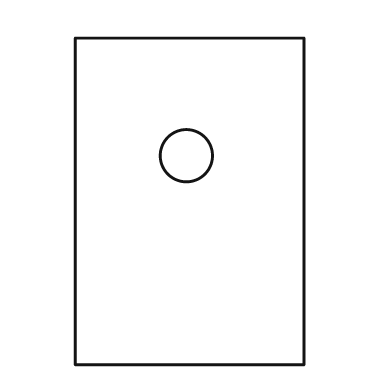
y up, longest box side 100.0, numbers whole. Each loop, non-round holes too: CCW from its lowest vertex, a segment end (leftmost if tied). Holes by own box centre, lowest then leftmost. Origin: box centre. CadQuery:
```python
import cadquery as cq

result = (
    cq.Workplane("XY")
    .moveTo(-35.0, -50.0)
    .lineTo(35.0, -50.0)
    .lineTo(35.0, 50.0)
    .lineTo(-35.0, 50.0)
    .close()
    .moveTo(-1.0, 14.0)
    .circle(8.0)
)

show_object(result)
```